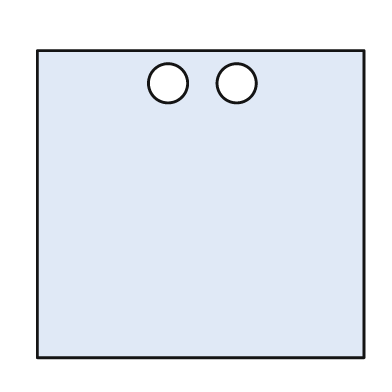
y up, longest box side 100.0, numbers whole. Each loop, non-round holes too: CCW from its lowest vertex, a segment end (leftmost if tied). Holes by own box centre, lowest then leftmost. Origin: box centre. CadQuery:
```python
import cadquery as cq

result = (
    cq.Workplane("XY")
    .moveTo(-50.0, -47.0)
    .lineTo(50.0, -47.0)
    .lineTo(50.0, 47.0)
    .lineTo(-50.0, 47.0)
    .close()
    .moveTo(-10.0, 37.0)
    .circle(6.0)
    .moveTo(11.0, 37.0)
    .circle(6.0)
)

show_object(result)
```